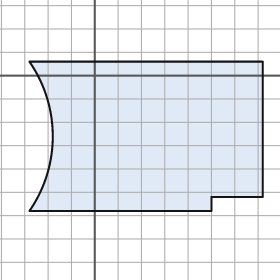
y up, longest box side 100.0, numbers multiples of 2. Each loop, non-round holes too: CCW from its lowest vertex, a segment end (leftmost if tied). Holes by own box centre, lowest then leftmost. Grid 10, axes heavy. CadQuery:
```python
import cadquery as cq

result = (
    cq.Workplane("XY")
    .moveTo(-28.0, -58.0)
    .lineTo(50.0, -58.0)
    .lineTo(50.0, -52.0)
    .lineTo(72.0, -52.0)
    .lineTo(72.0, 6.0)
    .lineTo(-28.0, 6.0)
    .threePointArc((-18.0, -26.0), (-28.0, -58.0))
    .close()
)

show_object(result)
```